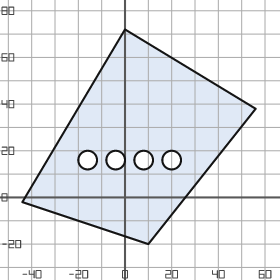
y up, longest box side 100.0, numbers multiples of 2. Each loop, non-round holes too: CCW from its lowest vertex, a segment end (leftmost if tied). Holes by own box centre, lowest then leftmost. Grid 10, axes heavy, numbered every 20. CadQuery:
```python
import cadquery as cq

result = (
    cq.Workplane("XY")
    .moveTo(10.0, -20.0)
    .lineTo(56.0, 38.0)
    .lineTo(0.0, 72.0)
    .lineTo(-44.0, -2.0)
    .close()
    .moveTo(-16.0, 16.0)
    .circle(4.0)
    .moveTo(-4.0, 16.0)
    .circle(4.0)
    .moveTo(8.0, 16.0)
    .circle(4.0)
    .moveTo(20.0, 16.0)
    .circle(4.0)
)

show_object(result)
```